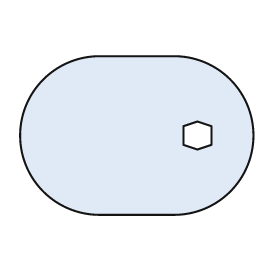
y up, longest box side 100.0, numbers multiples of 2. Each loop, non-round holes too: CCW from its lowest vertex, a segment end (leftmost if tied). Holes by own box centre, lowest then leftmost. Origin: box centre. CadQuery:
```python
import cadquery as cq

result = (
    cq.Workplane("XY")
    .moveTo(-16.0, -34.0)
    .lineTo(16.0, -34.0)
    .threePointArc((50.0, 0.0), (16.0, 34.0))
    .lineTo(-16.0, 34.0)
    .threePointArc((-50.0, 0.0), (-16.0, -34.0))
    .close()
    .moveTo(26.0, -6.0)
    .lineTo(32.0, -4.0)
    .lineTo(32.0, 4.0)
    .lineTo(26.0, 6.0)
    .lineTo(20.0, 4.0)
    .lineTo(20.0, -4.0)
    .close()
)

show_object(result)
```